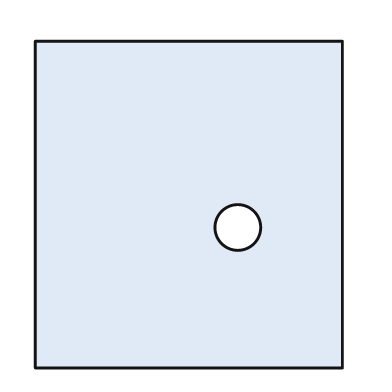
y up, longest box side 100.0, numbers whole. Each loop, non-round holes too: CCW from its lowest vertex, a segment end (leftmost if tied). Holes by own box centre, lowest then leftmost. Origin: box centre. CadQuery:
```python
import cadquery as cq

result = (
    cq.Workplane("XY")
    .moveTo(-47.0, -50.0)
    .lineTo(47.0, -50.0)
    .lineTo(47.0, 50.0)
    .lineTo(-47.0, 50.0)
    .close()
    .moveTo(15.0, -7.0)
    .circle(7.0)
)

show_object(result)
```